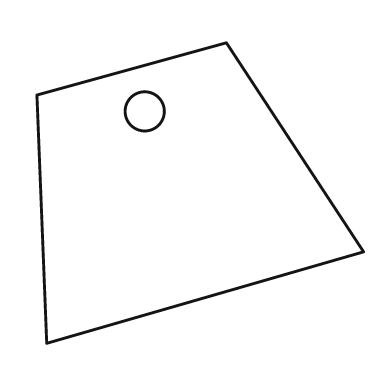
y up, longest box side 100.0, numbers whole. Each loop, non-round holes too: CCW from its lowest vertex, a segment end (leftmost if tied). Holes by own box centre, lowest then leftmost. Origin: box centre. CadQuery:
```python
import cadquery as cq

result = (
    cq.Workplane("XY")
    .moveTo(-47.0, -46.0)
    .lineTo(50.0, -18.0)
    .lineTo(8.0, 46.0)
    .lineTo(-50.0, 30.0)
    .close()
    .moveTo(-17.0, 25.0)
    .circle(6.0)
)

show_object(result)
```